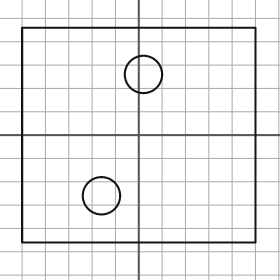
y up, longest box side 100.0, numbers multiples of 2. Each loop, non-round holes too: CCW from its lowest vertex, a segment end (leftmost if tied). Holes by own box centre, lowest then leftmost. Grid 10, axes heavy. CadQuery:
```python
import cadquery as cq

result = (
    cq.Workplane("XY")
    .moveTo(-50.0, -46.0)
    .lineTo(50.0, -46.0)
    .lineTo(50.0, 46.0)
    .lineTo(-50.0, 46.0)
    .close()
    .moveTo(-16.0, -26.0)
    .circle(8.0)
    .moveTo(2.0, 26.0)
    .circle(8.0)
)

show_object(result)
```